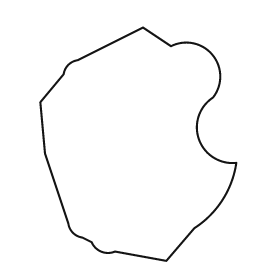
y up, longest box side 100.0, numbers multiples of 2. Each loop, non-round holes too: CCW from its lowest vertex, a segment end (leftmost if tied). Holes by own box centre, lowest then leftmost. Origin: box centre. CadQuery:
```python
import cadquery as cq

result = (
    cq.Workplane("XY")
    .moveTo(12.0, -50.0)
    .lineTo(24.0, -36.0)
    .threePointArc((36.0, -24.0), (42.0, -8.0))
    .threePointArc((26.0, 2.0), (32.0, 20.0))
    .threePointArc((32.0, 38.0), (14.0, 42.0))
    .lineTo(2.0, 50.0)
    .lineTo(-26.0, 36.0)
    .threePointArc((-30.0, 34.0), (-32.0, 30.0))
    .lineTo(-42.0, 18.0)
    .lineTo(-40.0, -4.0)
    .lineTo(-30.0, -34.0)
    .threePointArc((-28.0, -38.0), (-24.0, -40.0))
    .lineTo(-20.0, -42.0)
    .threePointArc((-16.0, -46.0), (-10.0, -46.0))
    .close()
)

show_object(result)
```